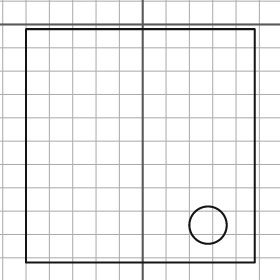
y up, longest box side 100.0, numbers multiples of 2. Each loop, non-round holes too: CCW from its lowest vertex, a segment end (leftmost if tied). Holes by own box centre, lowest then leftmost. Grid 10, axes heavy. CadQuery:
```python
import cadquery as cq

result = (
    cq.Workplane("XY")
    .moveTo(-50.0, -102.0)
    .lineTo(48.0, -102.0)
    .lineTo(48.0, -2.0)
    .lineTo(-50.0, -2.0)
    .close()
    .moveTo(28.0, -86.0)
    .circle(8.0)
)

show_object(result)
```